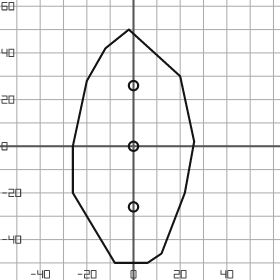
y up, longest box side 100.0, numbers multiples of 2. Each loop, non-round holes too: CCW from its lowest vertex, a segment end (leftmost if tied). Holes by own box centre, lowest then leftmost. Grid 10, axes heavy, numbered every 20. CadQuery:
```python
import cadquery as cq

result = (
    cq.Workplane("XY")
    .moveTo(-8.0, -50.0)
    .lineTo(6.0, -50.0)
    .lineTo(12.0, -46.0)
    .lineTo(22.0, -20.0)
    .lineTo(26.0, 2.0)
    .lineTo(20.0, 30.0)
    .lineTo(-2.0, 50.0)
    .lineTo(-12.0, 42.0)
    .lineTo(-20.0, 28.0)
    .lineTo(-26.0, 0.0)
    .lineTo(-26.0, -20.0)
    .close()
    .moveTo(0.0, -26.0)
    .circle(2.0)
    .moveTo(0.0, 0.0)
    .circle(2.0)
    .moveTo(0.0, 26.0)
    .circle(2.0)
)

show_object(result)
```